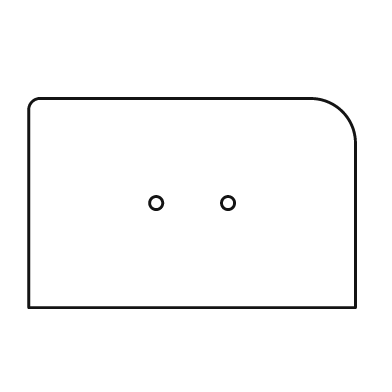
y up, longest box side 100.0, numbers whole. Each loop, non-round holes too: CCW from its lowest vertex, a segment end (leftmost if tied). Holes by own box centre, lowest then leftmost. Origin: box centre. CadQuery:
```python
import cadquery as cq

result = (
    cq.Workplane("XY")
    .moveTo(-50.0, -32.0)
    .lineTo(50.0, -32.0)
    .lineTo(50.0, 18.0)
    .threePointArc((46.0, 28.0), (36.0, 32.0))
    .lineTo(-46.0, 32.0)
    .threePointArc((-49.0, 31.0), (-50.0, 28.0))
    .close()
    .moveTo(-11.0, 0.0)
    .circle(2.0)
    .moveTo(11.0, 0.0)
    .circle(2.0)
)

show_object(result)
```